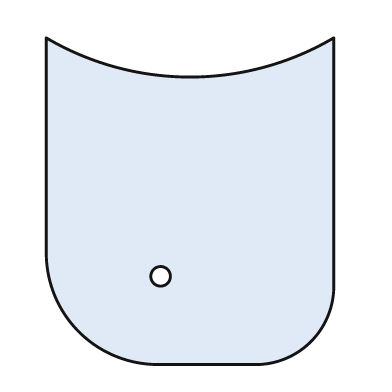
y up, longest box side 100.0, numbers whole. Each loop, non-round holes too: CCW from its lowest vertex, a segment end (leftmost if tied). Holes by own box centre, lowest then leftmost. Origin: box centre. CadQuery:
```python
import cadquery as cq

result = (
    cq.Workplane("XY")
    .moveTo(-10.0, -50.0)
    .lineTo(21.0, -50.0)
    .threePointArc((37.0, -43.0), (44.0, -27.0))
    .lineTo(44.0, 50.0)
    .threePointArc((0.0, 38.0), (-44.0, 50.0))
    .lineTo(-44.0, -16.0)
    .threePointArc((-34.0, -40.0), (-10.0, -50.0))
    .close()
    .moveTo(-9.0, -23.0)
    .circle(3.0)
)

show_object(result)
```